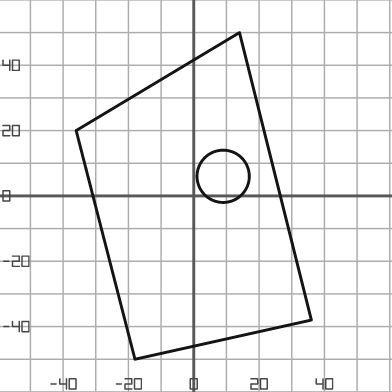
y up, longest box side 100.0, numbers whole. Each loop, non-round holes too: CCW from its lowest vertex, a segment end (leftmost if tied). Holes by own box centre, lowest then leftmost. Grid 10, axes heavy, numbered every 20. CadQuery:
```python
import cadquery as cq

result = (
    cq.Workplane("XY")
    .moveTo(-18.0, -50.0)
    .lineTo(36.0, -38.0)
    .lineTo(14.0, 50.0)
    .lineTo(-36.0, 20.0)
    .close()
    .moveTo(9.0, 6.0)
    .circle(8.0)
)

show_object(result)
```